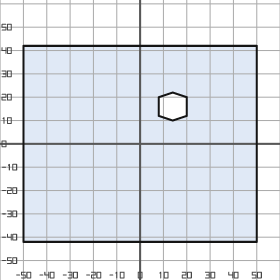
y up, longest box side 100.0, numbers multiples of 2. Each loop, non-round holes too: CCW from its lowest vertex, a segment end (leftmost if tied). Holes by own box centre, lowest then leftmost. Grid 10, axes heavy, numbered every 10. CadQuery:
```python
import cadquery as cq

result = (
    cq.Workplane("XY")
    .moveTo(-50.0, -42.0)
    .lineTo(50.0, -42.0)
    .lineTo(50.0, 42.0)
    .lineTo(-50.0, 42.0)
    .close()
    .moveTo(14.0, 10.0)
    .lineTo(20.0, 12.0)
    .lineTo(20.0, 20.0)
    .lineTo(14.0, 22.0)
    .lineTo(8.0, 20.0)
    .lineTo(8.0, 12.0)
    .close()
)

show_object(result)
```